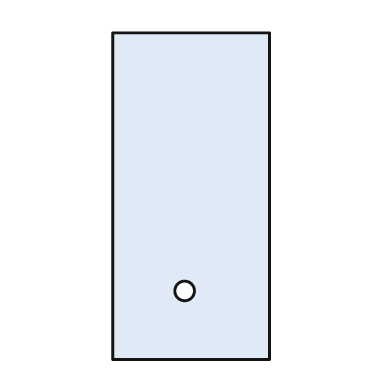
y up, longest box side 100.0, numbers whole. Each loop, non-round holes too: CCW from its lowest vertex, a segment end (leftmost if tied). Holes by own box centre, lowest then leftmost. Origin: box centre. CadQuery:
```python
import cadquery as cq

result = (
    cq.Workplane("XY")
    .moveTo(-24.0, -50.0)
    .lineTo(24.0, -50.0)
    .lineTo(24.0, 50.0)
    .lineTo(-24.0, 50.0)
    .close()
    .moveTo(-2.0, -29.0)
    .circle(3.0)
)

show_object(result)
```